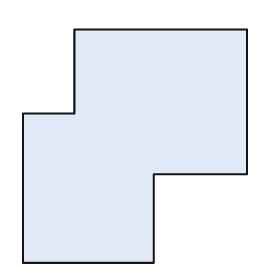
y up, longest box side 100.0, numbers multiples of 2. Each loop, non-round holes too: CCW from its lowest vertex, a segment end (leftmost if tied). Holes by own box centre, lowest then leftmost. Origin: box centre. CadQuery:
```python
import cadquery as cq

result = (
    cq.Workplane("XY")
    .moveTo(-48.0, -50.0)
    .lineTo(8.0, -50.0)
    .lineTo(8.0, -12.0)
    .lineTo(48.0, -12.0)
    .lineTo(48.0, 50.0)
    .lineTo(-26.0, 50.0)
    .lineTo(-26.0, 14.0)
    .lineTo(-48.0, 14.0)
    .close()
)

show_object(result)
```